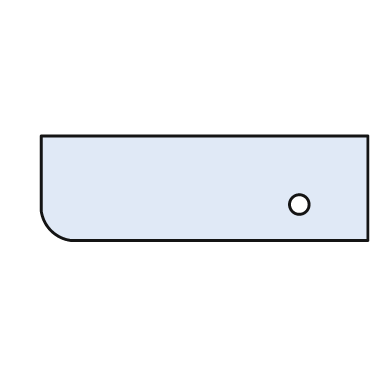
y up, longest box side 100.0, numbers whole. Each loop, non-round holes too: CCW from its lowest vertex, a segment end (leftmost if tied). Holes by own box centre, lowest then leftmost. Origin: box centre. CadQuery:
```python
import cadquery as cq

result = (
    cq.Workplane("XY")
    .moveTo(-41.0, -16.0)
    .lineTo(50.0, -16.0)
    .lineTo(50.0, 16.0)
    .lineTo(-50.0, 16.0)
    .lineTo(-50.0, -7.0)
    .threePointArc((-47.0, -13.0), (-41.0, -16.0))
    .close()
    .moveTo(29.0, -5.0)
    .circle(3.0)
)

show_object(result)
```